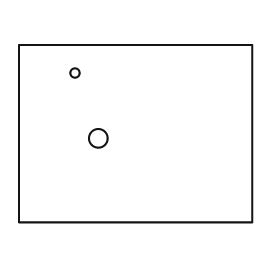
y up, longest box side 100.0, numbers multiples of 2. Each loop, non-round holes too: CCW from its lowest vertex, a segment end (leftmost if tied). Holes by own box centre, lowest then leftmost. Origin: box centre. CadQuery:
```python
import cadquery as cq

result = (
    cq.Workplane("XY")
    .moveTo(-50.0, -38.0)
    .lineTo(50.0, -38.0)
    .lineTo(50.0, 38.0)
    .lineTo(-50.0, 38.0)
    .close()
    .moveTo(-16.0, -2.0)
    .circle(4.0)
    .moveTo(-26.0, 26.0)
    .circle(2.0)
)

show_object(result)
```